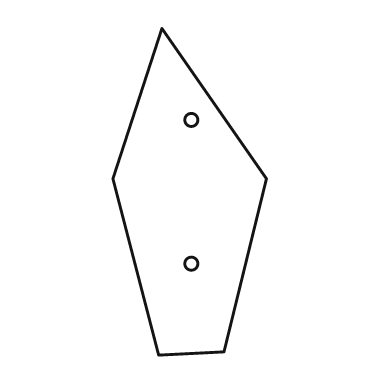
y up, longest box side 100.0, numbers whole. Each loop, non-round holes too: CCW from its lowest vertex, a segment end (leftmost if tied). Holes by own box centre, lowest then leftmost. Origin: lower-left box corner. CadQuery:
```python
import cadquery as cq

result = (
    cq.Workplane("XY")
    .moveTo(14.0, 0.0)
    .lineTo(34.0, 1.0)
    .lineTo(47.0, 54.0)
    .lineTo(15.0, 100.0)
    .lineTo(0.0, 54.0)
    .close()
    .moveTo(24.0, 28.0)
    .circle(2.0)
    .moveTo(24.0, 72.0)
    .circle(2.0)
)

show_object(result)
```